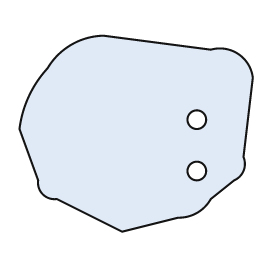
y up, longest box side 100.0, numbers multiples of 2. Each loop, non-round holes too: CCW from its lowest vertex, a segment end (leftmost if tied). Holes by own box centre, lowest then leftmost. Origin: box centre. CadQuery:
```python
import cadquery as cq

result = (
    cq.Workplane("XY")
    .moveTo(-6.0, -42.0)
    .lineTo(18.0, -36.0)
    .threePointArc((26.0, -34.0), (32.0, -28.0))
    .lineTo(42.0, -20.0)
    .threePointArc((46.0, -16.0), (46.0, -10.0))
    .lineTo(50.0, 24.0)
    .threePointArc((44.0, 34.0), (32.0, 36.0))
    .lineTo(-14.0, 42.0)
    .threePointArc((-28.0, 38.0), (-38.0, 28.0))
    .threePointArc((-46.0, 16.0), (-50.0, 2.0))
    .lineTo(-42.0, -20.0)
    .threePointArc((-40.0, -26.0), (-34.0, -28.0))
    .close()
    .moveTo(26.0, -16.0)
    .circle(4.0)
    .moveTo(26.0, 6.0)
    .circle(4.0)
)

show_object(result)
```